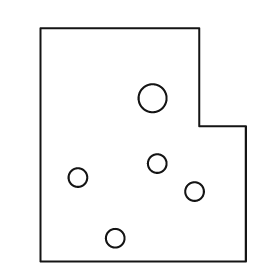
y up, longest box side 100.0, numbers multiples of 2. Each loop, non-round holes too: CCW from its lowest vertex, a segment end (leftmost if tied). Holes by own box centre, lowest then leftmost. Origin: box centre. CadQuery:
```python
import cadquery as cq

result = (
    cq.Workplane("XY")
    .moveTo(-44.0, -50.0)
    .lineTo(44.0, -50.0)
    .lineTo(44.0, 8.0)
    .lineTo(24.0, 8.0)
    .lineTo(24.0, 50.0)
    .lineTo(-44.0, 50.0)
    .close()
    .moveTo(-12.0, -40.0)
    .circle(4.0)
    .moveTo(22.0, -20.0)
    .circle(4.0)
    .moveTo(-28.0, -14.0)
    .circle(4.0)
    .moveTo(6.0, -8.0)
    .circle(4.0)
    .moveTo(4.0, 20.0)
    .circle(6.0)
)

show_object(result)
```